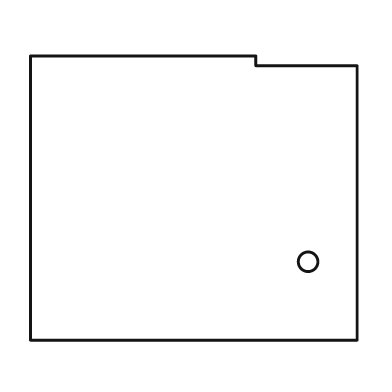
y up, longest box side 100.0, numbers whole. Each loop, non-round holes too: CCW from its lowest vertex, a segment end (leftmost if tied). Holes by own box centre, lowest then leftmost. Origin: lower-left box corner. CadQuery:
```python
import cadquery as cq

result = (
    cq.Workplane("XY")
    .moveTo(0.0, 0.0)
    .lineTo(100.0, 0.0)
    .lineTo(100.0, 84.0)
    .lineTo(69.0, 84.0)
    .lineTo(69.0, 87.0)
    .lineTo(0.0, 87.0)
    .close()
    .moveTo(85.0, 24.0)
    .circle(3.0)
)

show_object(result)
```